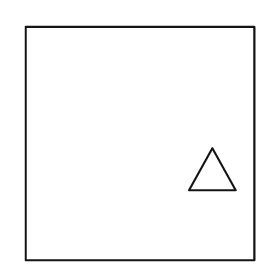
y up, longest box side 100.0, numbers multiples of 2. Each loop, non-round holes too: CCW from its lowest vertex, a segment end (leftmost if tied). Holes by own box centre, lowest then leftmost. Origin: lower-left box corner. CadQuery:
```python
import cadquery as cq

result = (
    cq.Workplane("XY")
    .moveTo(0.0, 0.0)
    .lineTo(98.0, 0.0)
    .lineTo(98.0, 100.0)
    .lineTo(0.0, 100.0)
    .close()
    .moveTo(70.0, 30.0)
    .lineTo(90.0, 30.0)
    .lineTo(80.0, 48.0)
    .close()
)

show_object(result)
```